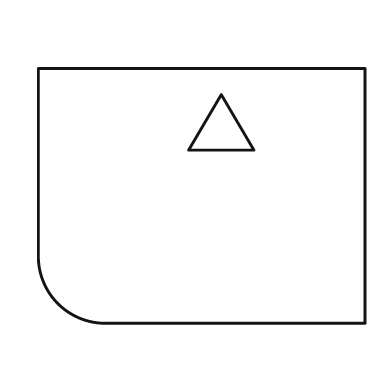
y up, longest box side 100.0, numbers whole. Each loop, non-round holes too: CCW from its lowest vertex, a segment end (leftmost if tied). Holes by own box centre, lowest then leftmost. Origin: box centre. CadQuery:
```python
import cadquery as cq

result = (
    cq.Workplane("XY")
    .moveTo(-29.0, -39.0)
    .lineTo(50.0, -39.0)
    .lineTo(50.0, 39.0)
    .lineTo(-50.0, 39.0)
    .lineTo(-50.0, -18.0)
    .threePointArc((-44.0, -33.0), (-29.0, -39.0))
    .close()
    .moveTo(-4.0, 14.0)
    .lineTo(16.0, 14.0)
    .lineTo(6.0, 31.0)
    .close()
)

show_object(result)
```